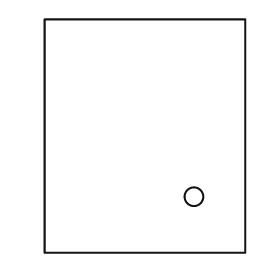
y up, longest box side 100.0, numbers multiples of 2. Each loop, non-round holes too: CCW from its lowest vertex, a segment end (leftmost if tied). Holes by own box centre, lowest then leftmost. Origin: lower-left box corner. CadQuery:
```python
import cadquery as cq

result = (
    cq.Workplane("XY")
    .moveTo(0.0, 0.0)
    .lineTo(86.0, 0.0)
    .lineTo(86.0, 100.0)
    .lineTo(0.0, 100.0)
    .close()
    .moveTo(64.0, 24.0)
    .circle(4.0)
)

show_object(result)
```